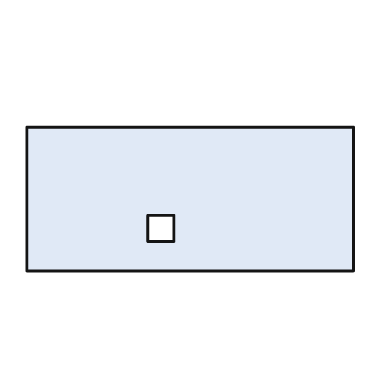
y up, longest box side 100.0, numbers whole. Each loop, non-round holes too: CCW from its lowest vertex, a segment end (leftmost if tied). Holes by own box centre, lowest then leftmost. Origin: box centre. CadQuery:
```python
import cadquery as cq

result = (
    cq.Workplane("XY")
    .moveTo(-50.0, -22.0)
    .lineTo(50.0, -22.0)
    .lineTo(50.0, 22.0)
    .lineTo(-50.0, 22.0)
    .close()
    .moveTo(-13.0, -13.0)
    .lineTo(-5.0, -13.0)
    .lineTo(-5.0, -5.0)
    .lineTo(-13.0, -5.0)
    .close()
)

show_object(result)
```